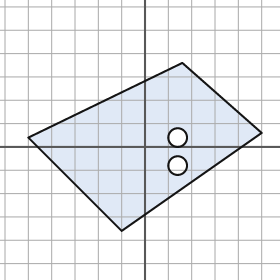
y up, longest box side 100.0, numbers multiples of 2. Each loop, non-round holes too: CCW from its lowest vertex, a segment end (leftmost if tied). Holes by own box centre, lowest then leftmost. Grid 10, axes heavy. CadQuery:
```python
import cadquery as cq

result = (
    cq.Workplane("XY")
    .moveTo(-10.0, -36.0)
    .lineTo(50.0, 6.0)
    .lineTo(16.0, 36.0)
    .lineTo(-50.0, 4.0)
    .close()
    .moveTo(14.0, -8.0)
    .circle(4.0)
    .moveTo(14.0, 4.0)
    .circle(4.0)
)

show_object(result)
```